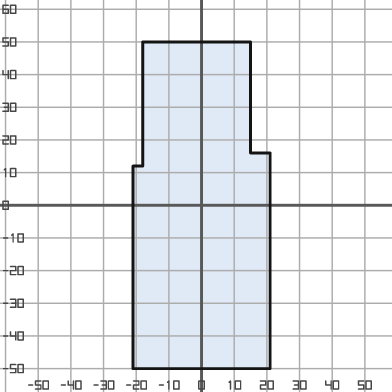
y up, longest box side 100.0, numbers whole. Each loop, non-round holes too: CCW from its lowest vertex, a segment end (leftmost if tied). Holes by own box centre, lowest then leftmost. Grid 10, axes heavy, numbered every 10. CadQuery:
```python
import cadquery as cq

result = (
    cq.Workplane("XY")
    .moveTo(-21.0, -50.0)
    .lineTo(21.0, -50.0)
    .lineTo(21.0, 16.0)
    .lineTo(15.0, 16.0)
    .lineTo(15.0, 50.0)
    .lineTo(-18.0, 50.0)
    .lineTo(-18.0, 12.0)
    .lineTo(-21.0, 12.0)
    .close()
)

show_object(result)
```